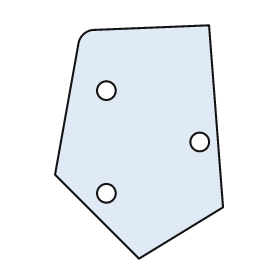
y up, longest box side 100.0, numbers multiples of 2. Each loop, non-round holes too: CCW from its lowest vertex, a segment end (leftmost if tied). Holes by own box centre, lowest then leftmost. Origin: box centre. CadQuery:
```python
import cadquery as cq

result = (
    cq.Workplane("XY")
    .moveTo(0.0, -50.0)
    .lineTo(36.0, -28.0)
    .lineTo(30.0, 50.0)
    .lineTo(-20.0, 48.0)
    .threePointArc((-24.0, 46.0), (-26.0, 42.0))
    .lineTo(-36.0, -14.0)
    .close()
    .moveTo(-14.0, -22.0)
    .circle(4.0)
    .moveTo(26.0, 0.0)
    .circle(4.0)
    .moveTo(-14.0, 22.0)
    .circle(4.0)
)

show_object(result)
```